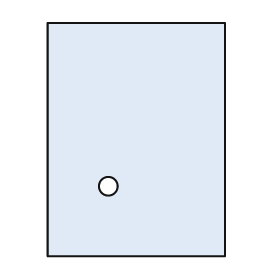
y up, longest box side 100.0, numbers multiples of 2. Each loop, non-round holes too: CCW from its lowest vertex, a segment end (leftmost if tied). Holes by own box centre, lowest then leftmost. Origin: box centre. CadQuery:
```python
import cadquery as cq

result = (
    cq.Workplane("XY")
    .moveTo(-38.0, -50.0)
    .lineTo(38.0, -50.0)
    .lineTo(38.0, 50.0)
    .lineTo(-38.0, 50.0)
    .close()
    .moveTo(-12.0, -20.0)
    .circle(4.0)
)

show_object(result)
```